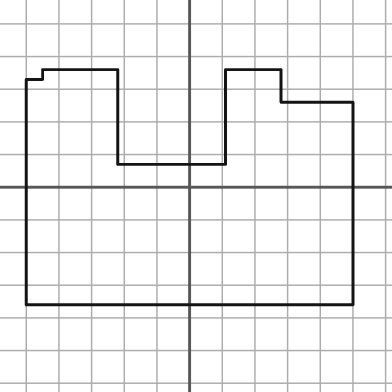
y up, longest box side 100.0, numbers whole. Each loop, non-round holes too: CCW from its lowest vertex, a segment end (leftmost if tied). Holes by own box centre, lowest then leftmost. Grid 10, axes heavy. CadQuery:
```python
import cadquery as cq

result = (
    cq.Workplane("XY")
    .moveTo(-50.0, -36.0)
    .lineTo(50.0, -36.0)
    .lineTo(50.0, 26.0)
    .lineTo(28.0, 26.0)
    .lineTo(28.0, 36.0)
    .lineTo(11.0, 36.0)
    .lineTo(11.0, 7.0)
    .lineTo(-22.0, 7.0)
    .lineTo(-22.0, 36.0)
    .lineTo(-45.0, 36.0)
    .lineTo(-45.0, 33.0)
    .lineTo(-50.0, 33.0)
    .close()
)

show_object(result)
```